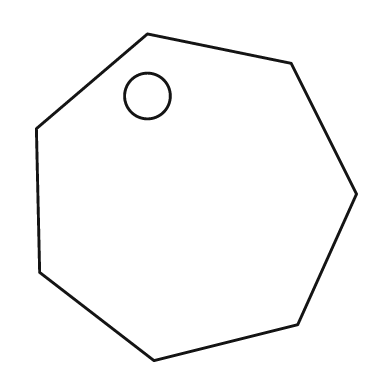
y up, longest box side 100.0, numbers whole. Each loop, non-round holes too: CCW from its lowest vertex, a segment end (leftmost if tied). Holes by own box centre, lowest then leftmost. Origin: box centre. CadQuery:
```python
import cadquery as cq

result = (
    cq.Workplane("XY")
    .moveTo(-13.0, -50.0)
    .lineTo(31.0, -39.0)
    .lineTo(49.0, 1.0)
    .lineTo(29.0, 41.0)
    .lineTo(-15.0, 50.0)
    .lineTo(-49.0, 21.0)
    .lineTo(-48.0, -23.0)
    .close()
    .moveTo(-15.0, 31.0)
    .circle(7.0)
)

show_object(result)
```